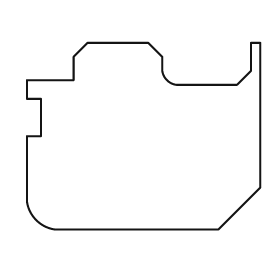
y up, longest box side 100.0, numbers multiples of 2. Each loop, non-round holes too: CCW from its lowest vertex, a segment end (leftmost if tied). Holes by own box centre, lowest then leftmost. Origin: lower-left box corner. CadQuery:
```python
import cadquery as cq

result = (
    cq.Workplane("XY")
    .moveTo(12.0, 0.0)
    .lineTo(82.0, 0.0)
    .lineTo(100.0, 18.0)
    .lineTo(100.0, 80.0)
    .lineTo(96.0, 80.0)
    .lineTo(96.0, 68.0)
    .lineTo(90.0, 62.0)
    .lineTo(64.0, 62.0)
    .threePointArc((60.0, 64.0), (58.0, 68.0))
    .lineTo(58.0, 74.0)
    .lineTo(52.0, 80.0)
    .lineTo(26.0, 80.0)
    .lineTo(20.0, 74.0)
    .lineTo(20.0, 64.0)
    .lineTo(0.0, 64.0)
    .lineTo(0.0, 56.0)
    .lineTo(6.0, 56.0)
    .lineTo(6.0, 40.0)
    .lineTo(0.0, 40.0)
    .lineTo(0.0, 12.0)
    .threePointArc((4.0, 4.0), (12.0, 0.0))
    .close()
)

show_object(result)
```